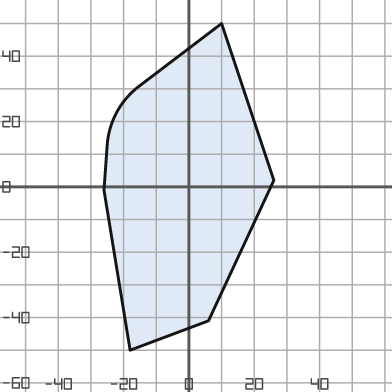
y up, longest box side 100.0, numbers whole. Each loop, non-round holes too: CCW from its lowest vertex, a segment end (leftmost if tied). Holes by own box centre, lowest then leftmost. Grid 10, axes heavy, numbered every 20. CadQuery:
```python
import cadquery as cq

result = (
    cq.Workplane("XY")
    .moveTo(-18.0, -50.0)
    .lineTo(6.0, -41.0)
    .lineTo(26.0, 2.0)
    .lineTo(10.0, 50.0)
    .lineTo(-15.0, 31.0)
    .threePointArc((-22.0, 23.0), (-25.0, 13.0))
    .lineTo(-26.0, -1.0)
    .close()
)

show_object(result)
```